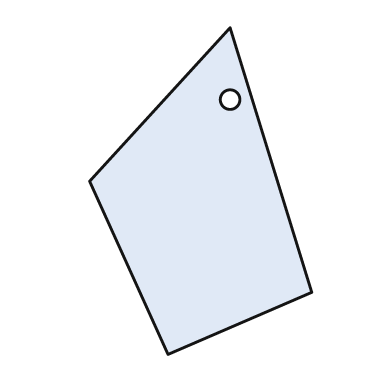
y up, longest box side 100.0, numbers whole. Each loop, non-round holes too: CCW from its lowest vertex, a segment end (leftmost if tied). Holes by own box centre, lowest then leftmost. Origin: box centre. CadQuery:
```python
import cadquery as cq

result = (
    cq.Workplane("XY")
    .moveTo(-10.0, -50.0)
    .lineTo(34.0, -31.0)
    .lineTo(9.0, 50.0)
    .lineTo(-34.0, 3.0)
    .close()
    .moveTo(9.0, 28.0)
    .circle(3.0)
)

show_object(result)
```